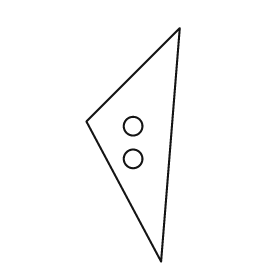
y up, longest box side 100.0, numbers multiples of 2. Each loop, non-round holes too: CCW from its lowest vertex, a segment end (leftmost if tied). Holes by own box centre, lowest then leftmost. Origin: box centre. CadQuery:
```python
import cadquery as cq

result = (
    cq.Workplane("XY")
    .moveTo(12.0, -50.0)
    .lineTo(20.0, 50.0)
    .lineTo(-20.0, 10.0)
    .close()
    .moveTo(0.0, -6.0)
    .circle(4.0)
    .moveTo(0.0, 8.0)
    .circle(4.0)
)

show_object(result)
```